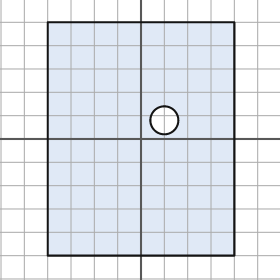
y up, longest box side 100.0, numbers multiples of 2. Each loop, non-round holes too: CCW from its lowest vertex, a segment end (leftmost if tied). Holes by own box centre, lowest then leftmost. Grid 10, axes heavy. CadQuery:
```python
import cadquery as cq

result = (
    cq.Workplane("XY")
    .moveTo(-40.0, -50.0)
    .lineTo(40.0, -50.0)
    .lineTo(40.0, 50.0)
    .lineTo(-40.0, 50.0)
    .close()
    .moveTo(10.0, 8.0)
    .circle(6.0)
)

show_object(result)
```